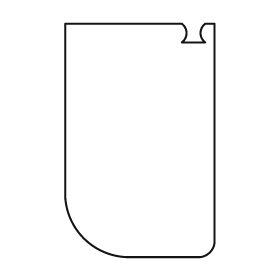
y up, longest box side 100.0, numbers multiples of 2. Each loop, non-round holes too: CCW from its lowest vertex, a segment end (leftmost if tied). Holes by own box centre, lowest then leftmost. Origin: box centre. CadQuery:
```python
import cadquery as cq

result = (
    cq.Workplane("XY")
    .moveTo(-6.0, -50.0)
    .lineTo(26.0, -50.0)
    .threePointArc((30.0, -48.0), (32.0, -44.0))
    .lineTo(32.0, 50.0)
    .lineTo(28.0, 50.0)
    .threePointArc((26.0, 46.0), (28.0, 42.0))
    .lineTo(18.0, 42.0)
    .threePointArc((20.0, 46.0), (18.0, 50.0))
    .lineTo(-32.0, 50.0)
    .lineTo(-32.0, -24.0)
    .threePointArc((-24.0, -42.0), (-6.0, -50.0))
    .close()
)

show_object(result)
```